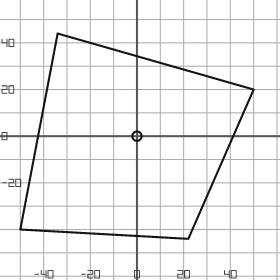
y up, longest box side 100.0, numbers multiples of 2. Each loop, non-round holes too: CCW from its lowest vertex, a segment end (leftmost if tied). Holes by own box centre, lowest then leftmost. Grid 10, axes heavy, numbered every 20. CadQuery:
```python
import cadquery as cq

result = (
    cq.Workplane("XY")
    .moveTo(22.0, -44.0)
    .lineTo(50.0, 20.0)
    .lineTo(-34.0, 44.0)
    .lineTo(-50.0, -40.0)
    .close()
    .moveTo(0.0, 0.0)
    .circle(2.0)
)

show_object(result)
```